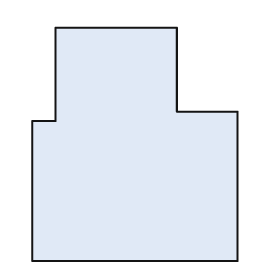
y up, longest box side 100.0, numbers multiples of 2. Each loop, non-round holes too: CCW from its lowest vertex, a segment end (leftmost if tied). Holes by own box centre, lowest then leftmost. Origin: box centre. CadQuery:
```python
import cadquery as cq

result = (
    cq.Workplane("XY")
    .moveTo(-44.0, -50.0)
    .lineTo(44.0, -50.0)
    .lineTo(44.0, 14.0)
    .lineTo(18.0, 14.0)
    .lineTo(18.0, 50.0)
    .lineTo(-34.0, 50.0)
    .lineTo(-34.0, 10.0)
    .lineTo(-44.0, 10.0)
    .close()
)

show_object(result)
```